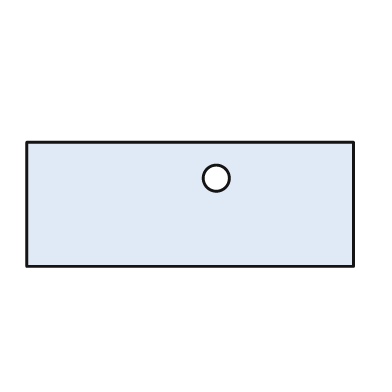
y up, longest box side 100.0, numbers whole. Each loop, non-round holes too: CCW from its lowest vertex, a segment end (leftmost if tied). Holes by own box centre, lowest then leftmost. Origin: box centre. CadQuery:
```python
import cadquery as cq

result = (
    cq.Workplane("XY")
    .moveTo(-50.0, -19.0)
    .lineTo(50.0, -19.0)
    .lineTo(50.0, 19.0)
    .lineTo(-50.0, 19.0)
    .close()
    .moveTo(8.0, 8.0)
    .circle(4.0)
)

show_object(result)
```